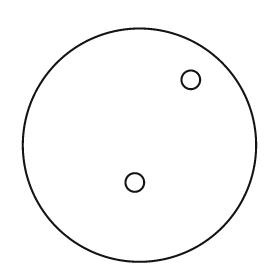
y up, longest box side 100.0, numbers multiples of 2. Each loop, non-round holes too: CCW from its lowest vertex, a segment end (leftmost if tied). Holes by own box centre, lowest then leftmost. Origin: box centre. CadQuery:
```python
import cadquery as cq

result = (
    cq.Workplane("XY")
    .moveTo(0.0, 0.0)
    .circle(50.0)
    .moveTo(-2.0, -16.0)
    .circle(4.0)
    .moveTo(22.0, 28.0)
    .circle(4.0)
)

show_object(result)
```